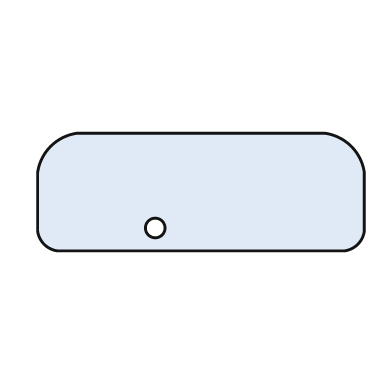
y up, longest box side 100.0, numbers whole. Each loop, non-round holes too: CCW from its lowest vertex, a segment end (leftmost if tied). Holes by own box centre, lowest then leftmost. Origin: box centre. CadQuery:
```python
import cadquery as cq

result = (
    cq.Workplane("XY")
    .moveTo(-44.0, -18.0)
    .lineTo(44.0, -18.0)
    .threePointArc((48.0, -16.0), (50.0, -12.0))
    .lineTo(50.0, 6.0)
    .threePointArc((46.0, 14.0), (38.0, 18.0))
    .lineTo(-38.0, 18.0)
    .threePointArc((-46.0, 14.0), (-50.0, 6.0))
    .lineTo(-50.0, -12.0)
    .threePointArc((-48.0, -16.0), (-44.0, -18.0))
    .close()
    .moveTo(-14.0, -11.0)
    .circle(3.0)
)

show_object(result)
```